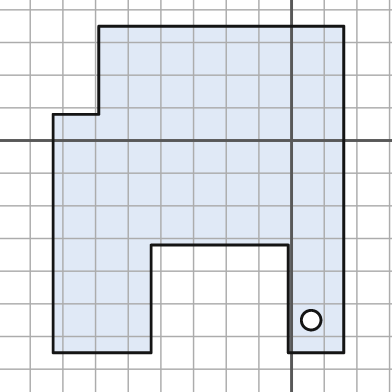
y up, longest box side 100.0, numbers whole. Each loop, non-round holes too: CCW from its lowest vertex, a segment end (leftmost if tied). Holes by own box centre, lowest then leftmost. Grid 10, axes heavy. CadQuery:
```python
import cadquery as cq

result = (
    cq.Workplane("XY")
    .moveTo(-73.0, -65.0)
    .lineTo(-43.0, -65.0)
    .lineTo(-43.0, -32.0)
    .lineTo(-1.0, -32.0)
    .lineTo(-1.0, -65.0)
    .lineTo(16.0, -65.0)
    .lineTo(16.0, 35.0)
    .lineTo(-59.0, 35.0)
    .lineTo(-59.0, 8.0)
    .lineTo(-73.0, 8.0)
    .close()
    .moveTo(6.0, -55.0)
    .circle(3.0)
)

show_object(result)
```